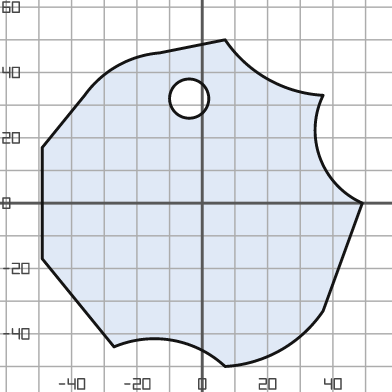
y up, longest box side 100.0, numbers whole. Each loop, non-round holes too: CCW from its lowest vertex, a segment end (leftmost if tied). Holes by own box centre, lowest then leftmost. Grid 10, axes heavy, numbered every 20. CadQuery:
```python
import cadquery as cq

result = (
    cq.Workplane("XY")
    .moveTo(7.0, -50.0)
    .threePointArc((24.0, -45.0), (37.0, -33.0))
    .lineTo(49.0, 0.0)
    .threePointArc((36.0, 14.0), (37.0, 33.0))
    .threePointArc((20.0, 38.0), (7.0, 50.0))
    .lineTo(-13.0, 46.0)
    .threePointArc((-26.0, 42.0), (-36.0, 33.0))
    .lineTo(-49.0, 17.0)
    .lineTo(-49.0, -17.0)
    .lineTo(-27.0, -44.0)
    .threePointArc((-9.0, -42.0), (7.0, -50.0))
    .close()
    .moveTo(-4.0, 32.0)
    .circle(6.0)
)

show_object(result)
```